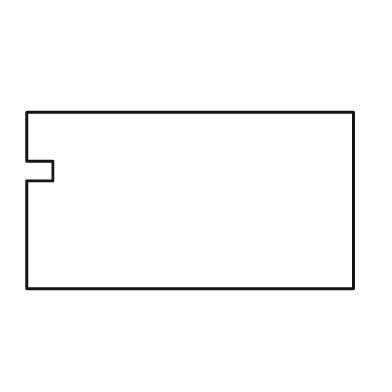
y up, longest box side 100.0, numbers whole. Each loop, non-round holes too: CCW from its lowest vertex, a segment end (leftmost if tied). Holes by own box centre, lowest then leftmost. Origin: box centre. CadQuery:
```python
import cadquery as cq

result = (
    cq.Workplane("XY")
    .moveTo(-50.0, -27.0)
    .lineTo(50.0, -27.0)
    .lineTo(50.0, 27.0)
    .lineTo(-50.0, 27.0)
    .lineTo(-50.0, 12.0)
    .lineTo(-42.0, 12.0)
    .lineTo(-42.0, 6.0)
    .lineTo(-50.0, 6.0)
    .close()
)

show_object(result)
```